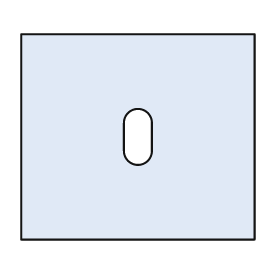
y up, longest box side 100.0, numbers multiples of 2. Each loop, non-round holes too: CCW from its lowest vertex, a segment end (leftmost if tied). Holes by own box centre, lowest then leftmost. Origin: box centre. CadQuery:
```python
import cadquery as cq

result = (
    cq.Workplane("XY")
    .moveTo(-50.0, -44.0)
    .lineTo(50.0, -44.0)
    .lineTo(50.0, 44.0)
    .lineTo(-50.0, 44.0)
    .close()
    .moveTo(-6.0, -6.0)
    .threePointArc((0.0, -12.0), (6.0, -6.0))
    .lineTo(6.0, 6.0)
    .threePointArc((0.0, 12.0), (-6.0, 6.0))
    .close()
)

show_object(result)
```